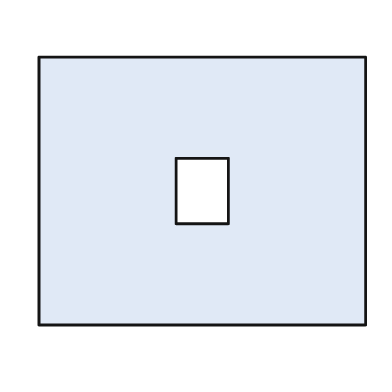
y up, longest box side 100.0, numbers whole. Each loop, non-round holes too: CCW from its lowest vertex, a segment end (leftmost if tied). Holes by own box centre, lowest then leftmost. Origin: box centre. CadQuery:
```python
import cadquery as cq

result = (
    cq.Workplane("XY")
    .moveTo(-50.0, -41.0)
    .lineTo(50.0, -41.0)
    .lineTo(50.0, 41.0)
    .lineTo(-50.0, 41.0)
    .close()
    .moveTo(-8.0, -10.0)
    .lineTo(8.0, -10.0)
    .lineTo(8.0, 10.0)
    .lineTo(-8.0, 10.0)
    .close()
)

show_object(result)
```